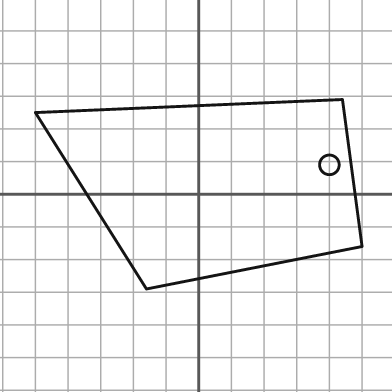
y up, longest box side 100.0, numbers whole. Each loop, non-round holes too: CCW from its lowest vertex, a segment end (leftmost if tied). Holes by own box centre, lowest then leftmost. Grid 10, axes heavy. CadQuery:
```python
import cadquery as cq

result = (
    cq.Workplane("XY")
    .moveTo(-16.0, -29.0)
    .lineTo(50.0, -16.0)
    .lineTo(44.0, 29.0)
    .lineTo(-50.0, 25.0)
    .close()
    .moveTo(40.0, 9.0)
    .circle(3.0)
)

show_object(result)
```